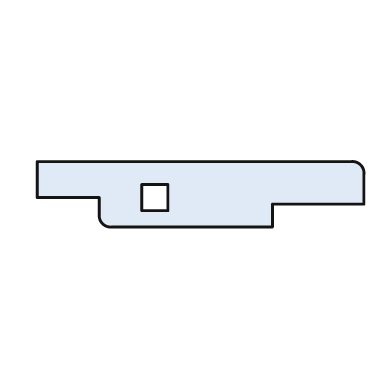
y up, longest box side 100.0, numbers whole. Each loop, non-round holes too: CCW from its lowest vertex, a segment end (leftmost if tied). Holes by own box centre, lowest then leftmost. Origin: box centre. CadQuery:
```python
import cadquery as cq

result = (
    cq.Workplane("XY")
    .moveTo(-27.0, -10.0)
    .lineTo(22.0, -10.0)
    .lineTo(22.0, -3.0)
    .lineTo(50.0, -3.0)
    .lineTo(50.0, 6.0)
    .threePointArc((49.0, 9.0), (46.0, 10.0))
    .lineTo(-50.0, 10.0)
    .lineTo(-50.0, -1.0)
    .lineTo(-31.0, -1.0)
    .lineTo(-31.0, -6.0)
    .threePointArc((-30.0, -9.0), (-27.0, -10.0))
    .close()
    .moveTo(-18.0, -5.0)
    .lineTo(-10.0, -5.0)
    .lineTo(-10.0, 3.0)
    .lineTo(-18.0, 3.0)
    .close()
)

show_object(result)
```